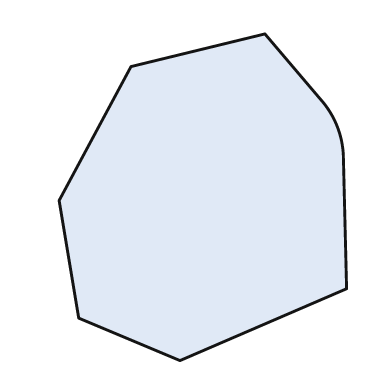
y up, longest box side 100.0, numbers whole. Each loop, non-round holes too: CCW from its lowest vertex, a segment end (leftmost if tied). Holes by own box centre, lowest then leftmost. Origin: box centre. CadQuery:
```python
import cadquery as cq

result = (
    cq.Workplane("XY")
    .moveTo(-7.0, -50.0)
    .lineTo(44.0, -28.0)
    .lineTo(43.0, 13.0)
    .threePointArc((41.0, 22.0), (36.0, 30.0))
    .lineTo(19.0, 50.0)
    .lineTo(-22.0, 40.0)
    .lineTo(-44.0, -1.0)
    .lineTo(-38.0, -37.0)
    .close()
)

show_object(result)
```